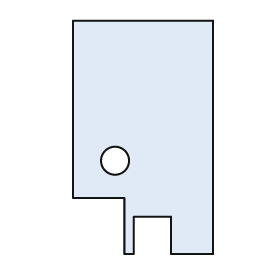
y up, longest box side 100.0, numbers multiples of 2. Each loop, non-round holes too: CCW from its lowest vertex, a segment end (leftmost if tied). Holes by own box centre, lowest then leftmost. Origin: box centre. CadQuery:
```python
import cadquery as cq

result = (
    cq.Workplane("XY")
    .moveTo(-8.0, -50.0)
    .lineTo(-4.0, -50.0)
    .lineTo(-4.0, -34.0)
    .lineTo(12.0, -34.0)
    .lineTo(12.0, -50.0)
    .lineTo(30.0, -50.0)
    .lineTo(30.0, 50.0)
    .lineTo(-30.0, 50.0)
    .lineTo(-30.0, -26.0)
    .lineTo(-8.0, -26.0)
    .close()
    .moveTo(-12.0, -10.0)
    .circle(6.0)
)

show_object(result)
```